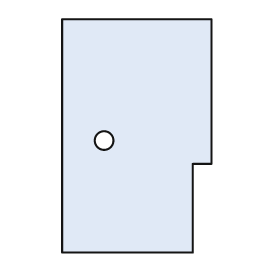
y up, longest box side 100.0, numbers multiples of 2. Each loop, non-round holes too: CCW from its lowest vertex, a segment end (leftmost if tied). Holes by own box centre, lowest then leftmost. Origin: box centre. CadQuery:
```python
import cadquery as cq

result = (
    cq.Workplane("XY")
    .moveTo(-32.0, -50.0)
    .lineTo(24.0, -50.0)
    .lineTo(24.0, -12.0)
    .lineTo(32.0, -12.0)
    .lineTo(32.0, 50.0)
    .lineTo(-32.0, 50.0)
    .close()
    .moveTo(-14.0, -2.0)
    .circle(4.0)
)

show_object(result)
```